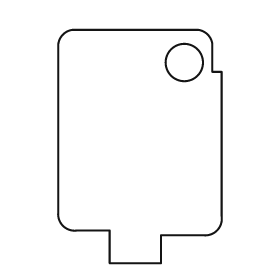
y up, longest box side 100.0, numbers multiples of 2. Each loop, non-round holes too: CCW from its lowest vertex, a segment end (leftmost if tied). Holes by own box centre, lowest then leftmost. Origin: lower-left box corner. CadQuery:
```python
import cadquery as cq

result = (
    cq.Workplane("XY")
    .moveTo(22.0, 0.0)
    .lineTo(44.0, 0.0)
    .lineTo(44.0, 12.0)
    .lineTo(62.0, 12.0)
    .threePointArc((68.0, 14.0), (70.0, 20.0))
    .lineTo(70.0, 82.0)
    .lineTo(66.0, 82.0)
    .lineTo(66.0, 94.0)
    .threePointArc((64.0, 98.0), (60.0, 100.0))
    .lineTo(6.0, 100.0)
    .threePointArc((2.0, 98.0), (0.0, 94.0))
    .lineTo(0.0, 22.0)
    .threePointArc((2.0, 16.0), (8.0, 14.0))
    .lineTo(22.0, 14.0)
    .close()
    .moveTo(54.0, 86.0)
    .circle(8.0)
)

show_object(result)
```